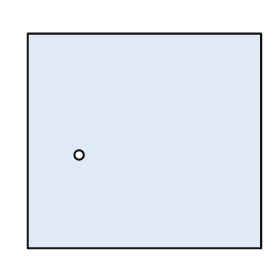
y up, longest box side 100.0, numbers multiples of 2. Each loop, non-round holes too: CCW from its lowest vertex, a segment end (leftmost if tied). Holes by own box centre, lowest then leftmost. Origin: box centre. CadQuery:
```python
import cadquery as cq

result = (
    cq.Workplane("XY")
    .moveTo(-50.0, -46.0)
    .lineTo(50.0, -46.0)
    .lineTo(50.0, 46.0)
    .lineTo(-50.0, 46.0)
    .close()
    .moveTo(-28.0, -6.0)
    .circle(2.0)
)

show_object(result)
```